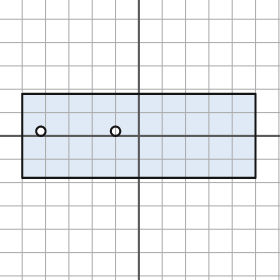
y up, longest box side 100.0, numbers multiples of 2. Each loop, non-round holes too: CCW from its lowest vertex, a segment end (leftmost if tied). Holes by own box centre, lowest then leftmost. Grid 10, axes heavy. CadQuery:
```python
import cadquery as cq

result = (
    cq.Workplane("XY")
    .moveTo(-50.0, -18.0)
    .lineTo(50.0, -18.0)
    .lineTo(50.0, 18.0)
    .lineTo(-50.0, 18.0)
    .close()
    .moveTo(-42.0, 2.0)
    .circle(2.0)
    .moveTo(-10.0, 2.0)
    .circle(2.0)
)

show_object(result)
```